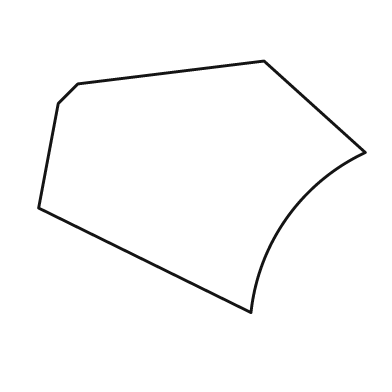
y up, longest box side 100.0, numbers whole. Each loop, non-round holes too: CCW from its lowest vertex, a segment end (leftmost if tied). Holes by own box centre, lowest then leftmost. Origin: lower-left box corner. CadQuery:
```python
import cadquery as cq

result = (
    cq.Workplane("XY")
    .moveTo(65.0, 0.0)
    .threePointArc((76.0, 29.0), (100.0, 49.0))
    .lineTo(69.0, 77.0)
    .lineTo(12.0, 70.0)
    .lineTo(6.0, 64.0)
    .lineTo(0.0, 32.0)
    .close()
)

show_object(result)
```